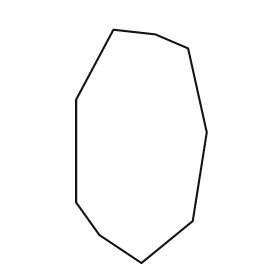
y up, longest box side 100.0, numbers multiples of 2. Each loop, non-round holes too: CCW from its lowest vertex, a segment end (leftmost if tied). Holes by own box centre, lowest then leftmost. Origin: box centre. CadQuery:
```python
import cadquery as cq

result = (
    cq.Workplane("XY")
    .moveTo(0.0, -50.0)
    .lineTo(22.0, -32.0)
    .lineTo(28.0, 6.0)
    .lineTo(20.0, 42.0)
    .lineTo(6.0, 48.0)
    .lineTo(-12.0, 50.0)
    .lineTo(-28.0, 20.0)
    .lineTo(-28.0, -24.0)
    .lineTo(-18.0, -38.0)
    .close()
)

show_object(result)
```